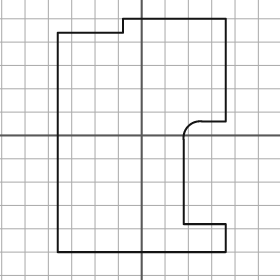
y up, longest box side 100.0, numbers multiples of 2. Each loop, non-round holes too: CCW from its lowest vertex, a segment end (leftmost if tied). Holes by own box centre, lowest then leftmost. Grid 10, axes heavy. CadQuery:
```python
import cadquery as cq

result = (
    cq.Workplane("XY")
    .moveTo(-36.0, -50.0)
    .lineTo(36.0, -50.0)
    .lineTo(36.0, -38.0)
    .lineTo(18.0, -38.0)
    .lineTo(18.0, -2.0)
    .threePointArc((20.0, 4.0), (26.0, 6.0))
    .lineTo(36.0, 6.0)
    .lineTo(36.0, 50.0)
    .lineTo(-8.0, 50.0)
    .lineTo(-8.0, 44.0)
    .lineTo(-36.0, 44.0)
    .close()
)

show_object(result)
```